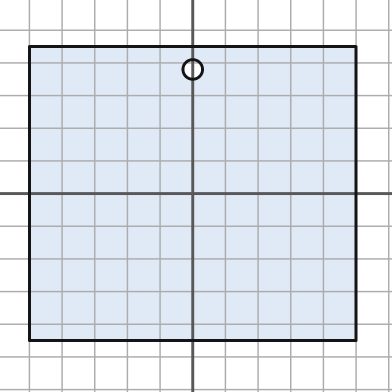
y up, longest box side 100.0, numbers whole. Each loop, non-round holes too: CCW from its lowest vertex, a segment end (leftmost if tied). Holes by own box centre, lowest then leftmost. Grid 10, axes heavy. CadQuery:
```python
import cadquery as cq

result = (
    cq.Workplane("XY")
    .moveTo(-50.0, -45.0)
    .lineTo(50.0, -45.0)
    .lineTo(50.0, 45.0)
    .lineTo(-50.0, 45.0)
    .close()
    .moveTo(0.0, 38.0)
    .circle(3.0)
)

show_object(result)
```